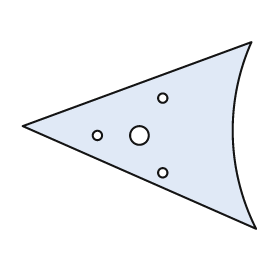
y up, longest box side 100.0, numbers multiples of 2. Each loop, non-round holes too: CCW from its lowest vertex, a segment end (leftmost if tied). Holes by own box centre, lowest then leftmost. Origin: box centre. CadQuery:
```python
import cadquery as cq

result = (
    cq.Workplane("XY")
    .moveTo(50.0, -40.0)
    .threePointArc((40.0, 0.0), (48.0, 40.0))
    .lineTo(-50.0, 4.0)
    .close()
    .moveTo(10.0, -16.0)
    .circle(2.0)
    .moveTo(-18.0, 0.0)
    .circle(2.0)
    .moveTo(0.0, 0.0)
    .circle(4.0)
    .moveTo(10.0, 16.0)
    .circle(2.0)
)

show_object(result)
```